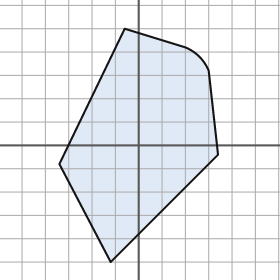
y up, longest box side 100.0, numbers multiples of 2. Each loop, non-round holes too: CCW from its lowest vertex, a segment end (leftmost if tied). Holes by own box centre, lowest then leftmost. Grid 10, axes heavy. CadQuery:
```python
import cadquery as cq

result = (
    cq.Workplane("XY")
    .moveTo(-12.0, -50.0)
    .lineTo(34.0, -4.0)
    .lineTo(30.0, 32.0)
    .threePointArc((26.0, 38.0), (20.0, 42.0))
    .lineTo(-6.0, 50.0)
    .lineTo(-34.0, -8.0)
    .close()
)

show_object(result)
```